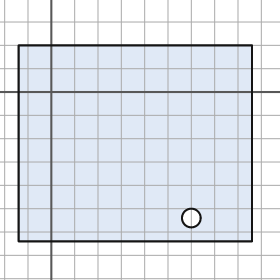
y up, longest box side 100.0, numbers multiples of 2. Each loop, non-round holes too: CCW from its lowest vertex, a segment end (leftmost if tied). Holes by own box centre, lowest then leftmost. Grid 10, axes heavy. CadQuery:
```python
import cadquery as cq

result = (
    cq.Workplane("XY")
    .moveTo(-14.0, -64.0)
    .lineTo(86.0, -64.0)
    .lineTo(86.0, 20.0)
    .lineTo(-14.0, 20.0)
    .close()
    .moveTo(60.0, -54.0)
    .circle(4.0)
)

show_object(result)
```